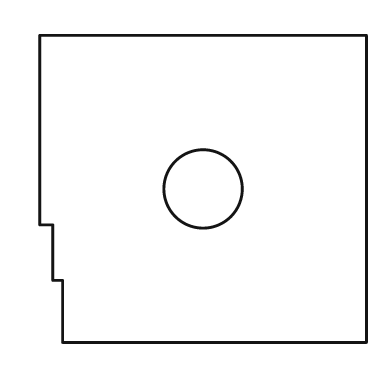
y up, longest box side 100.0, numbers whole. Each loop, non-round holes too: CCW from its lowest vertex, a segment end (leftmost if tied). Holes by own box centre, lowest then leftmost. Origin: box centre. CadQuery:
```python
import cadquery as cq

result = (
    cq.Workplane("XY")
    .moveTo(-43.0, -47.0)
    .lineTo(50.0, -47.0)
    .lineTo(50.0, 47.0)
    .lineTo(-50.0, 47.0)
    .lineTo(-50.0, -11.0)
    .lineTo(-46.0, -11.0)
    .lineTo(-46.0, -28.0)
    .lineTo(-43.0, -28.0)
    .close()
    .moveTo(0.0, 0.0)
    .circle(12.0)
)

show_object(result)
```